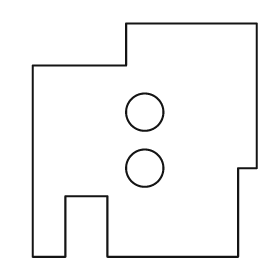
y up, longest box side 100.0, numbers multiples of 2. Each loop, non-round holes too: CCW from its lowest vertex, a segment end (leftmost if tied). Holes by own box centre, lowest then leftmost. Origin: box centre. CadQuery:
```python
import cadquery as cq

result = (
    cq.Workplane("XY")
    .moveTo(-48.0, -50.0)
    .lineTo(-34.0, -50.0)
    .lineTo(-34.0, -24.0)
    .lineTo(-16.0, -24.0)
    .lineTo(-16.0, -50.0)
    .lineTo(40.0, -50.0)
    .lineTo(40.0, -12.0)
    .lineTo(48.0, -12.0)
    .lineTo(48.0, 50.0)
    .lineTo(-8.0, 50.0)
    .lineTo(-8.0, 32.0)
    .lineTo(-48.0, 32.0)
    .close()
    .moveTo(0.0, -12.0)
    .circle(8.0)
    .moveTo(0.0, 12.0)
    .circle(8.0)
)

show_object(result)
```